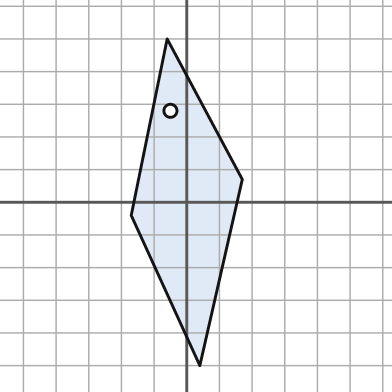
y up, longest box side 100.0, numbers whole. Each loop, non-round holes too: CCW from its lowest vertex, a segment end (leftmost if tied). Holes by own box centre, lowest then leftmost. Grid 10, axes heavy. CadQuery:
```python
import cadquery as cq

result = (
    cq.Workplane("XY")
    .moveTo(4.0, -50.0)
    .lineTo(17.0, 7.0)
    .lineTo(-6.0, 50.0)
    .lineTo(-17.0, -4.0)
    .close()
    .moveTo(-5.0, 28.0)
    .circle(2.0)
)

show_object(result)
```